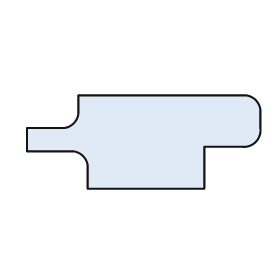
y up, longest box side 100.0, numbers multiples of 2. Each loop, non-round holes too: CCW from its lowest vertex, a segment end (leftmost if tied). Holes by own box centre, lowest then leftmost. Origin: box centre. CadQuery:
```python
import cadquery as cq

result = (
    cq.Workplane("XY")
    .moveTo(-24.0, -20.0)
    .lineTo(26.0, -20.0)
    .lineTo(26.0, -2.0)
    .lineTo(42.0, -2.0)
    .threePointArc((48.0, 0.0), (50.0, 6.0))
    .lineTo(50.0, 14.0)
    .threePointArc((48.0, 18.0), (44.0, 20.0))
    .lineTo(-28.0, 20.0)
    .lineTo(-28.0, 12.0)
    .threePointArc((-30.0, 8.0), (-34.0, 6.0))
    .lineTo(-50.0, 6.0)
    .lineTo(-50.0, -4.0)
    .lineTo(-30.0, -4.0)
    .threePointArc((-26.0, -6.0), (-24.0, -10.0))
    .close()
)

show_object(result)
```